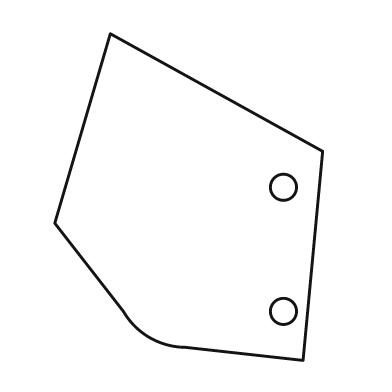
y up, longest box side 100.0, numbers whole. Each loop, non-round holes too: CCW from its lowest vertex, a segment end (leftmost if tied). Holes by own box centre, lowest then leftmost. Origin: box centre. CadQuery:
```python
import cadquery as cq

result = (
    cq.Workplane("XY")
    .moveTo(35.0, -50.0)
    .lineTo(41.0, 14.0)
    .lineTo(-24.0, 50.0)
    .lineTo(-41.0, -8.0)
    .lineTo(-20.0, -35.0)
    .threePointArc((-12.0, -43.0), (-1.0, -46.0))
    .close()
    .moveTo(29.0, -35.0)
    .circle(4.0)
    .moveTo(29.0, 3.0)
    .circle(4.0)
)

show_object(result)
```